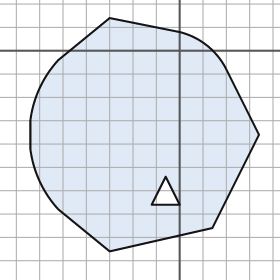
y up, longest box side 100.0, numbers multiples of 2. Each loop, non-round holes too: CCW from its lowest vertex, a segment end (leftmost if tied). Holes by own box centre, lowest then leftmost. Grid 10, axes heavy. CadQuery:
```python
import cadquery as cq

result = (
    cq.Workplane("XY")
    .moveTo(-30.0, -86.0)
    .lineTo(14.0, -76.0)
    .lineTo(34.0, -36.0)
    .lineTo(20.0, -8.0)
    .threePointArc((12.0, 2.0), (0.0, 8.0))
    .lineTo(-30.0, 14.0)
    .lineTo(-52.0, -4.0)
    .threePointArc((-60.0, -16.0), (-64.0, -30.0))
    .lineTo(-64.0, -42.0)
    .threePointArc((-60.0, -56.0), (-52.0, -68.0))
    .close()
    .moveTo(-12.0, -66.0)
    .lineTo(0.0, -66.0)
    .lineTo(-6.0, -54.0)
    .close()
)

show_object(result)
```